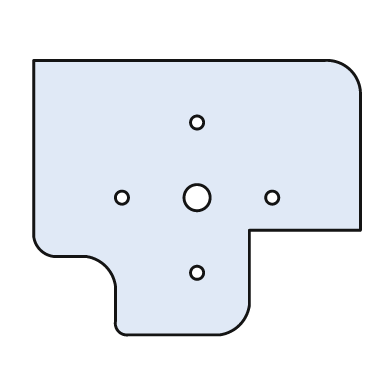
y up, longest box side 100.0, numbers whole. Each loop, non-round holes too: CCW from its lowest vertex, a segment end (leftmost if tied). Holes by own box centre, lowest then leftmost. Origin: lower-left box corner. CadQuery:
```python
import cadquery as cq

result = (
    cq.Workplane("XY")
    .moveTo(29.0, 0.0)
    .lineTo(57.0, 0.0)
    .threePointArc((63.0, 3.0), (66.0, 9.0))
    .lineTo(66.0, 32.0)
    .lineTo(100.0, 32.0)
    .lineTo(100.0, 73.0)
    .threePointArc((97.0, 81.0), (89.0, 84.0))
    .lineTo(0.0, 84.0)
    .lineTo(0.0, 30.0)
    .threePointArc((2.0, 26.0), (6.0, 24.0))
    .lineTo(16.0, 24.0)
    .threePointArc((22.0, 21.0), (25.0, 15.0))
    .lineTo(25.0, 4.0)
    .threePointArc((26.0, 1.0), (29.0, 0.0))
    .close()
    .moveTo(50.0, 19.0)
    .circle(2.0)
    .moveTo(27.0, 42.0)
    .circle(2.0)
    .moveTo(50.0, 42.0)
    .circle(4.0)
    .moveTo(73.0, 42.0)
    .circle(2.0)
    .moveTo(50.0, 65.0)
    .circle(2.0)
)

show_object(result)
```